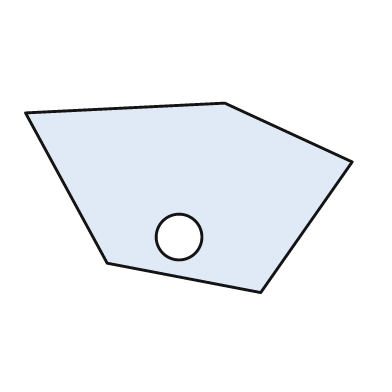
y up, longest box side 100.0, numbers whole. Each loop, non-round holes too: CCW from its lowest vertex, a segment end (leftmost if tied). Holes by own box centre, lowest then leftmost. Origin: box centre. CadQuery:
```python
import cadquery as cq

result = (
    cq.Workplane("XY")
    .moveTo(22.0, -29.0)
    .lineTo(50.0, 11.0)
    .lineTo(11.0, 29.0)
    .lineTo(-50.0, 26.0)
    .lineTo(-25.0, -20.0)
    .close()
    .moveTo(-3.0, -12.0)
    .circle(7.0)
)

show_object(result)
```